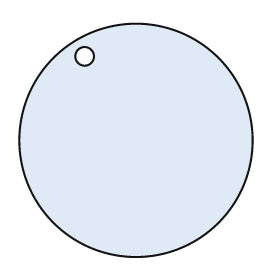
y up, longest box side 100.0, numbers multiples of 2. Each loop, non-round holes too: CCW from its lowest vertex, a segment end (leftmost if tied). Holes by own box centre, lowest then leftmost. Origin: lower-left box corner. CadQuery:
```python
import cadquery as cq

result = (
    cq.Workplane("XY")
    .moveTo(50.0, 50.0)
    .circle(50.0)
    .moveTo(28.0, 86.0)
    .circle(4.0)
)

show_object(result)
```